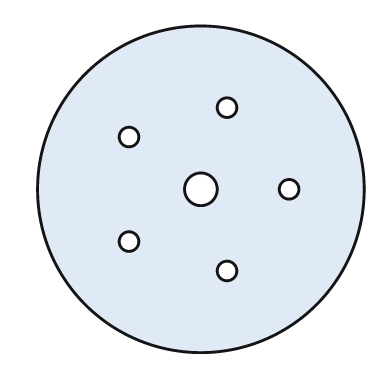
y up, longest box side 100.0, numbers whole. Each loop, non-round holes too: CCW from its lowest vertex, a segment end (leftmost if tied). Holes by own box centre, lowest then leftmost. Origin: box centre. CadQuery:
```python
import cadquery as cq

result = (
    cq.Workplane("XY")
    .moveTo(0.0, 0.0)
    .circle(50.0)
    .moveTo(8.0, -25.0)
    .circle(3.0)
    .moveTo(-22.0, -16.0)
    .circle(3.0)
    .moveTo(0.0, 0.0)
    .circle(5.0)
    .moveTo(27.0, 0.0)
    .circle(3.0)
    .moveTo(-22.0, 16.0)
    .circle(3.0)
    .moveTo(8.0, 25.0)
    .circle(3.0)
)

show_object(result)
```